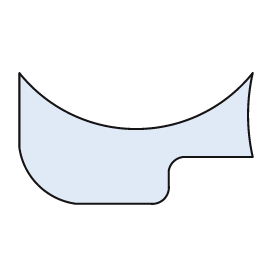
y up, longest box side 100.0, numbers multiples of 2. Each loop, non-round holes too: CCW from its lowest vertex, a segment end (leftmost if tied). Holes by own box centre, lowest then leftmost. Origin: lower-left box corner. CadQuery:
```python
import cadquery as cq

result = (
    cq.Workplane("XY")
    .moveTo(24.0, 0.0)
    .lineTo(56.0, 0.0)
    .threePointArc((62.0, 2.0), (64.0, 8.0))
    .lineTo(64.0, 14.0)
    .threePointArc((66.0, 18.0), (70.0, 20.0))
    .lineTo(100.0, 20.0)
    .threePointArc((98.0, 38.0), (100.0, 56.0))
    .threePointArc((50.0, 32.0), (0.0, 56.0))
    .lineTo(0.0, 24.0)
    .threePointArc((8.0, 8.0), (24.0, 0.0))
    .close()
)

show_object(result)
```